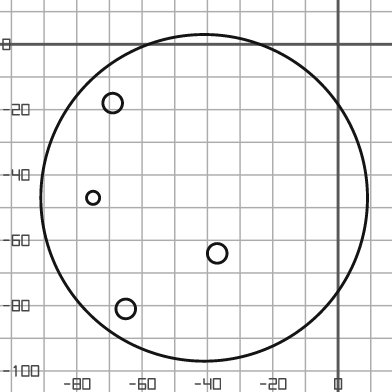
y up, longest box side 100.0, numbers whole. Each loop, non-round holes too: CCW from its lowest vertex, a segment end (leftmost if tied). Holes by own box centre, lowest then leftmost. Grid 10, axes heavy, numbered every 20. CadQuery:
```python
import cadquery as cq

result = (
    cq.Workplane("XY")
    .moveTo(-41.0, -47.0)
    .circle(50.0)
    .moveTo(-65.0, -81.0)
    .circle(3.0)
    .moveTo(-37.0, -64.0)
    .circle(3.0)
    .moveTo(-75.0, -47.0)
    .circle(2.0)
    .moveTo(-69.0, -18.0)
    .circle(3.0)
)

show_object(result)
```